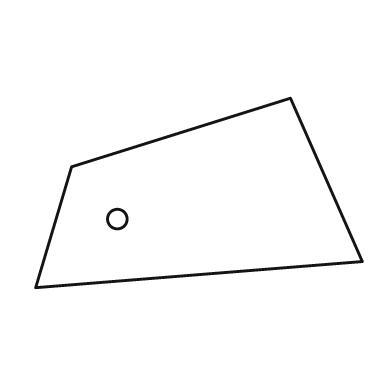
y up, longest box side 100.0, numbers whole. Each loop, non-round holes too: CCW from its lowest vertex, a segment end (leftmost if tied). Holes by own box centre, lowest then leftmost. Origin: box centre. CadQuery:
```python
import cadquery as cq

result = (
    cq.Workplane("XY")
    .moveTo(-50.0, -29.0)
    .lineTo(50.0, -21.0)
    .lineTo(28.0, 29.0)
    .lineTo(-39.0, 8.0)
    .close()
    .moveTo(-25.0, -8.0)
    .circle(3.0)
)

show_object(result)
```